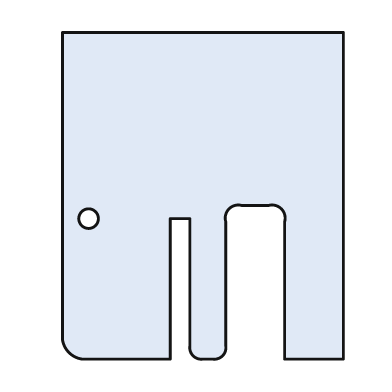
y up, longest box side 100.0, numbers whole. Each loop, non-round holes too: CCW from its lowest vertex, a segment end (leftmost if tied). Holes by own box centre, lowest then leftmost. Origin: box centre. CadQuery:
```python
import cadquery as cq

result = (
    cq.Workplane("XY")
    .moveTo(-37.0, -50.0)
    .lineTo(-10.0, -50.0)
    .lineTo(-10.0, -7.0)
    .lineTo(-4.0, -7.0)
    .lineTo(-4.0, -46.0)
    .threePointArc((-3.0, -49.0), (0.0, -50.0))
    .lineTo(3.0, -50.0)
    .threePointArc((6.0, -49.0), (7.0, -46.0))
    .lineTo(7.0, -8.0)
    .threePointArc((8.0, -4.0), (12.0, -3.0))
    .lineTo(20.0, -3.0)
    .threePointArc((24.0, -4.0), (25.0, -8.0))
    .lineTo(25.0, -50.0)
    .lineTo(43.0, -50.0)
    .lineTo(43.0, 50.0)
    .lineTo(-43.0, 50.0)
    .lineTo(-43.0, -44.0)
    .threePointArc((-41.0, -48.0), (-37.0, -50.0))
    .close()
    .moveTo(-35.0, -7.0)
    .circle(3.0)
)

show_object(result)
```